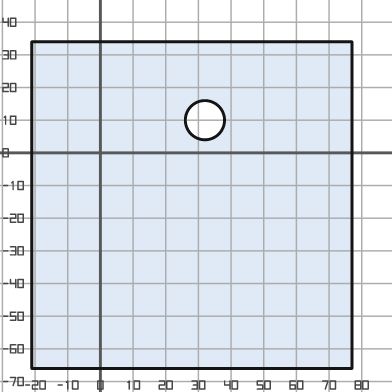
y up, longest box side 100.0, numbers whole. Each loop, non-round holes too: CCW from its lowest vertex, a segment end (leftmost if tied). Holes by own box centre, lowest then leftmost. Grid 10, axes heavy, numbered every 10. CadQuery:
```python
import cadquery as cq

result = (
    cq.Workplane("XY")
    .moveTo(-21.0, -66.0)
    .lineTo(77.0, -66.0)
    .lineTo(77.0, 34.0)
    .lineTo(-21.0, 34.0)
    .close()
    .moveTo(32.0, 10.0)
    .circle(6.0)
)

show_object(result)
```